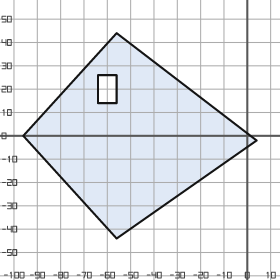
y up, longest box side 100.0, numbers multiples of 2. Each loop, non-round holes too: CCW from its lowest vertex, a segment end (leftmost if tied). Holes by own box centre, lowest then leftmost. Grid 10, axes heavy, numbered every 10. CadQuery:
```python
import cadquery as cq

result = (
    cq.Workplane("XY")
    .moveTo(-56.0, -44.0)
    .lineTo(4.0, -2.0)
    .lineTo(-56.0, 44.0)
    .lineTo(-96.0, 0.0)
    .close()
    .moveTo(-64.0, 14.0)
    .lineTo(-56.0, 14.0)
    .lineTo(-56.0, 26.0)
    .lineTo(-64.0, 26.0)
    .close()
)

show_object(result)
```